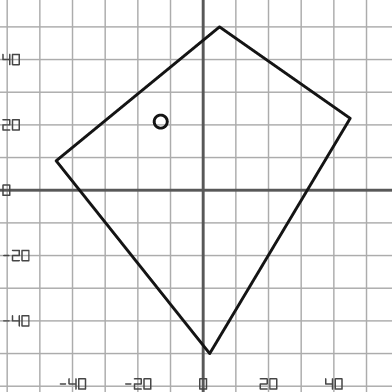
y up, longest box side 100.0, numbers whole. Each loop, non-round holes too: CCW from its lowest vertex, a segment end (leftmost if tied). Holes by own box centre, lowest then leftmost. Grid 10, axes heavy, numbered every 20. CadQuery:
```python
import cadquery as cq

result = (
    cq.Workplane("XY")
    .moveTo(2.0, -50.0)
    .lineTo(45.0, 22.0)
    .lineTo(5.0, 50.0)
    .lineTo(-45.0, 9.0)
    .close()
    .moveTo(-13.0, 21.0)
    .circle(2.0)
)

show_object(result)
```